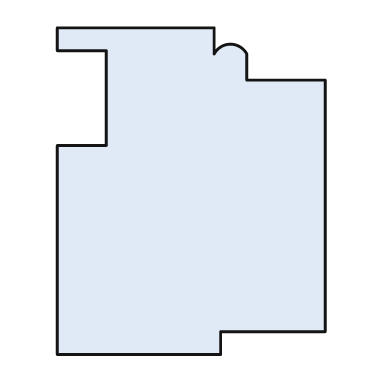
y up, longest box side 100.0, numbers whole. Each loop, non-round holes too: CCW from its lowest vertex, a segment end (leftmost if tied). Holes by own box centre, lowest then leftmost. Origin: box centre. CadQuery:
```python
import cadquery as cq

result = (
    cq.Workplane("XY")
    .moveTo(-41.0, -50.0)
    .lineTo(9.0, -50.0)
    .lineTo(9.0, -43.0)
    .lineTo(41.0, -43.0)
    .lineTo(41.0, 34.0)
    .lineTo(17.0, 34.0)
    .lineTo(17.0, 42.0)
    .threePointArc((12.0, 45.0), (7.0, 42.0))
    .lineTo(7.0, 50.0)
    .lineTo(-41.0, 50.0)
    .lineTo(-41.0, 43.0)
    .lineTo(-26.0, 43.0)
    .lineTo(-26.0, 14.0)
    .lineTo(-41.0, 14.0)
    .close()
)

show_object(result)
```